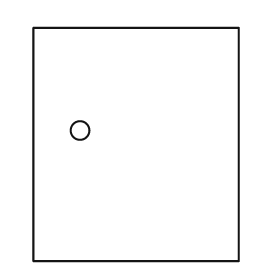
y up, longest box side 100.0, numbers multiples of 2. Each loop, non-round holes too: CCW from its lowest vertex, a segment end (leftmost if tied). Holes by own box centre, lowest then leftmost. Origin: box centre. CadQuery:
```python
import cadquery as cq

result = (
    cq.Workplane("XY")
    .moveTo(-44.0, -50.0)
    .lineTo(44.0, -50.0)
    .lineTo(44.0, 50.0)
    .lineTo(-44.0, 50.0)
    .close()
    .moveTo(-24.0, 6.0)
    .circle(4.0)
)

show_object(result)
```